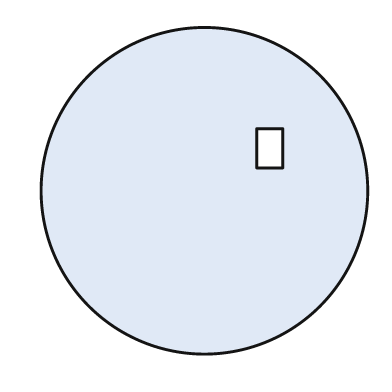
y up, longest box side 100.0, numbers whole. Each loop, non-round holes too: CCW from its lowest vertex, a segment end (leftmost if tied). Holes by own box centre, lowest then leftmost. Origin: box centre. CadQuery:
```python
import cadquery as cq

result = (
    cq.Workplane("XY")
    .moveTo(0.0, 0.0)
    .circle(50.0)
    .moveTo(16.0, 7.0)
    .lineTo(24.0, 7.0)
    .lineTo(24.0, 19.0)
    .lineTo(16.0, 19.0)
    .close()
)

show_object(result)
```